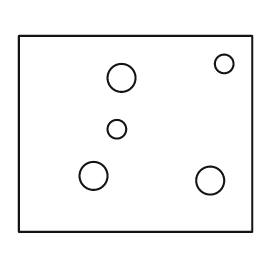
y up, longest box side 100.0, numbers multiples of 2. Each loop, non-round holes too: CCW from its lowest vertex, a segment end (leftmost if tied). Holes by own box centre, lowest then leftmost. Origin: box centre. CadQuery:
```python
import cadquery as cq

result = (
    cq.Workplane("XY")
    .moveTo(-50.0, -42.0)
    .lineTo(50.0, -42.0)
    .lineTo(50.0, 42.0)
    .lineTo(-50.0, 42.0)
    .close()
    .moveTo(32.0, -20.0)
    .circle(6.0)
    .moveTo(-18.0, -18.0)
    .circle(6.0)
    .moveTo(-8.0, 2.0)
    .circle(4.0)
    .moveTo(-6.0, 24.0)
    .circle(6.0)
    .moveTo(38.0, 30.0)
    .circle(4.0)
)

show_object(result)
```